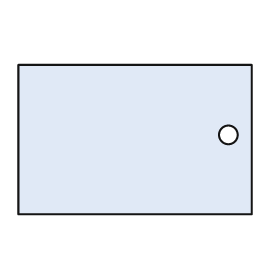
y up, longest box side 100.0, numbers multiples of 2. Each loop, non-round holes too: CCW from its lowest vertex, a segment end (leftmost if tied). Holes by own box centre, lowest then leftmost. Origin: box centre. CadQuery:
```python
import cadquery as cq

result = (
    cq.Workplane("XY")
    .moveTo(-50.0, -32.0)
    .lineTo(50.0, -32.0)
    .lineTo(50.0, 32.0)
    .lineTo(-50.0, 32.0)
    .close()
    .moveTo(40.0, 2.0)
    .circle(4.0)
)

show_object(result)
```